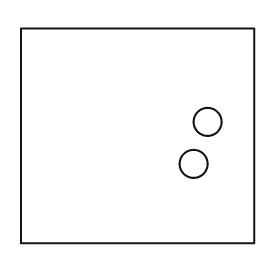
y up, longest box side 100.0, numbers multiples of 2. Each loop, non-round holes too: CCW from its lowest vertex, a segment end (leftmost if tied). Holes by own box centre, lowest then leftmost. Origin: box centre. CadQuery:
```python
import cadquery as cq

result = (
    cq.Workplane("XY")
    .moveTo(-50.0, -46.0)
    .lineTo(50.0, -46.0)
    .lineTo(50.0, 46.0)
    .lineTo(-50.0, 46.0)
    .close()
    .moveTo(24.0, -12.0)
    .circle(6.0)
    .moveTo(30.0, 6.0)
    .circle(6.0)
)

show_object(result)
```